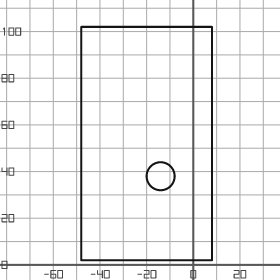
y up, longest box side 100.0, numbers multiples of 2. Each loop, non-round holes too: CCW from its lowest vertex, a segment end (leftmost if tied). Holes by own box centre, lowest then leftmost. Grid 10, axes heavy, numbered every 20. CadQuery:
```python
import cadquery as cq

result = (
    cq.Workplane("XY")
    .moveTo(-48.0, 2.0)
    .lineTo(8.0, 2.0)
    .lineTo(8.0, 102.0)
    .lineTo(-48.0, 102.0)
    .close()
    .moveTo(-14.0, 38.0)
    .circle(6.0)
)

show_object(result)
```